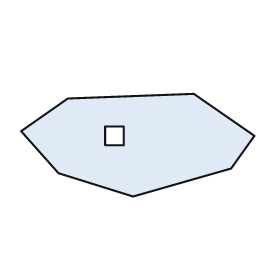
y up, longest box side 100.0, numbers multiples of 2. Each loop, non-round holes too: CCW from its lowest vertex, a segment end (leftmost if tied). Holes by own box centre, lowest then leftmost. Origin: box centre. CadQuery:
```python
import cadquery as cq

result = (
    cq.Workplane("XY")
    .moveTo(-2.0, -22.0)
    .lineTo(40.0, -10.0)
    .lineTo(50.0, 4.0)
    .lineTo(24.0, 22.0)
    .lineTo(-30.0, 20.0)
    .lineTo(-50.0, 6.0)
    .lineTo(-34.0, -12.0)
    .close()
    .moveTo(-14.0, 0.0)
    .lineTo(-6.0, 0.0)
    .lineTo(-6.0, 8.0)
    .lineTo(-14.0, 8.0)
    .close()
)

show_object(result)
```